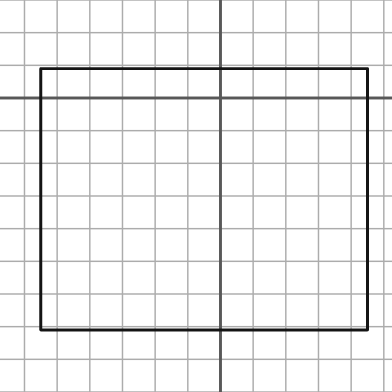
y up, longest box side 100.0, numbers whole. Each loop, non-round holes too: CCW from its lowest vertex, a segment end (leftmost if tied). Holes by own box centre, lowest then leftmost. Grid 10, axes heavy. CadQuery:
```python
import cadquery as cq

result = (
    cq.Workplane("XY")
    .moveTo(-55.0, -71.0)
    .lineTo(45.0, -71.0)
    .lineTo(45.0, 9.0)
    .lineTo(-55.0, 9.0)
    .close()
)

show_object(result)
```